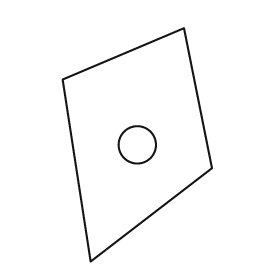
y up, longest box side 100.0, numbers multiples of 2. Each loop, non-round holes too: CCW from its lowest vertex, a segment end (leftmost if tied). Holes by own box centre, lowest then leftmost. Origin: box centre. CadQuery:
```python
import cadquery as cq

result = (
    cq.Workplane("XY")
    .moveTo(-20.0, -50.0)
    .lineTo(32.0, -10.0)
    .lineTo(20.0, 50.0)
    .lineTo(-32.0, 28.0)
    .close()
    .moveTo(0.0, 0.0)
    .circle(8.0)
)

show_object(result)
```